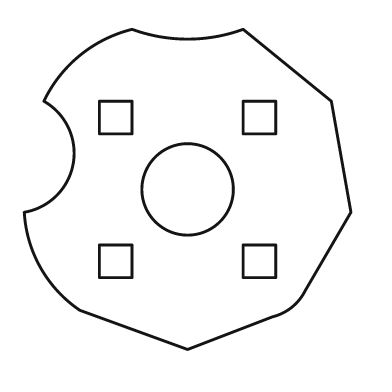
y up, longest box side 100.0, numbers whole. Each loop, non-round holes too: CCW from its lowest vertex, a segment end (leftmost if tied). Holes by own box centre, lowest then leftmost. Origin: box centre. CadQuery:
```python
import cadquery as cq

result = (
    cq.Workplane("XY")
    .moveTo(0.0, -49.0)
    .lineTo(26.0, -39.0)
    .threePointArc((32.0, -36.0), (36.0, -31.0))
    .lineTo(50.0, -7.0)
    .lineTo(44.0, 27.0)
    .lineTo(17.0, 49.0)
    .threePointArc((0.0, 46.0), (-17.0, 49.0))
    .threePointArc((-33.0, 41.0), (-44.0, 27.0))
    .threePointArc((-35.0, 8.0), (-50.0, -7.0))
    .threePointArc((-45.0, -24.0), (-33.0, -37.0))
    .close()
    .moveTo(-27.0, -27.0)
    .lineTo(-17.0, -27.0)
    .lineTo(-17.0, -17.0)
    .lineTo(-27.0, -17.0)
    .close()
    .moveTo(17.0, -27.0)
    .lineTo(27.0, -27.0)
    .lineTo(27.0, -17.0)
    .lineTo(17.0, -17.0)
    .close()
    .moveTo(0.0, 0.0)
    .circle(14.0)
    .moveTo(-27.0, 17.0)
    .lineTo(-17.0, 17.0)
    .lineTo(-17.0, 27.0)
    .lineTo(-27.0, 27.0)
    .close()
    .moveTo(17.0, 17.0)
    .lineTo(27.0, 17.0)
    .lineTo(27.0, 27.0)
    .lineTo(17.0, 27.0)
    .close()
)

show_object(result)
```